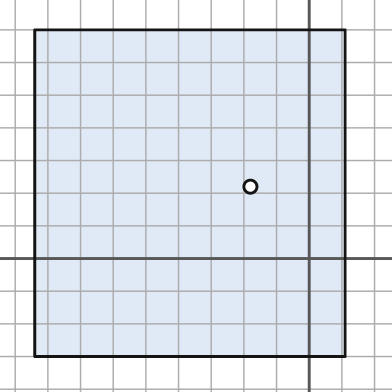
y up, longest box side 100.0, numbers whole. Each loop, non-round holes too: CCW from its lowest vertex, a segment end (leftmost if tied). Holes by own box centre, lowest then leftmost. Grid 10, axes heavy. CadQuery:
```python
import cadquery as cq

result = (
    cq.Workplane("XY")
    .moveTo(-84.0, -30.0)
    .lineTo(11.0, -30.0)
    .lineTo(11.0, 70.0)
    .lineTo(-84.0, 70.0)
    .close()
    .moveTo(-18.0, 22.0)
    .circle(2.0)
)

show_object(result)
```